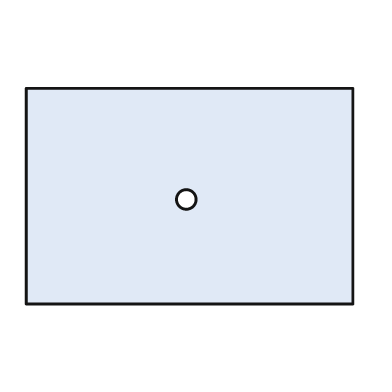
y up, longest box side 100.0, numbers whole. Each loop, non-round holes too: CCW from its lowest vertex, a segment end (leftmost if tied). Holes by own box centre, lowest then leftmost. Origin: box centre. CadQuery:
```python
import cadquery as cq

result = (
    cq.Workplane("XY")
    .moveTo(-50.0, -33.0)
    .lineTo(50.0, -33.0)
    .lineTo(50.0, 33.0)
    .lineTo(-50.0, 33.0)
    .close()
    .moveTo(-1.0, -1.0)
    .circle(3.0)
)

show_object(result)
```